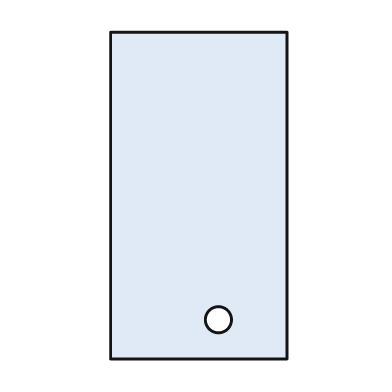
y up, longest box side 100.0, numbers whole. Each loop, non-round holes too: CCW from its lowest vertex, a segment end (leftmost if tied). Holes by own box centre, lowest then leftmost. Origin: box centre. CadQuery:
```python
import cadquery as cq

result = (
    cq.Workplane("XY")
    .moveTo(-27.0, -50.0)
    .lineTo(27.0, -50.0)
    .lineTo(27.0, 50.0)
    .lineTo(-27.0, 50.0)
    .close()
    .moveTo(6.0, -38.0)
    .circle(4.0)
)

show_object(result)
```